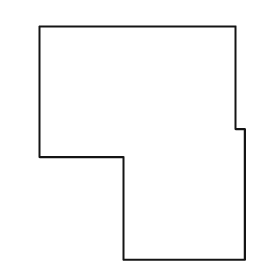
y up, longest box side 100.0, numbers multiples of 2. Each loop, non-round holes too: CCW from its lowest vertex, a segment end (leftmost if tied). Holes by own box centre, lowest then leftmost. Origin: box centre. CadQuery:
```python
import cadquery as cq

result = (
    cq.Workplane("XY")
    .moveTo(-8.0, -50.0)
    .lineTo(44.0, -50.0)
    .lineTo(44.0, 6.0)
    .lineTo(40.0, 6.0)
    .lineTo(40.0, 50.0)
    .lineTo(-44.0, 50.0)
    .lineTo(-44.0, -6.0)
    .lineTo(-8.0, -6.0)
    .close()
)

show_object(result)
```